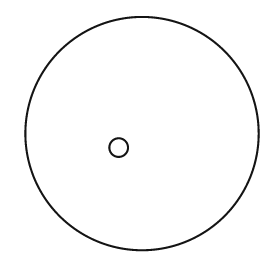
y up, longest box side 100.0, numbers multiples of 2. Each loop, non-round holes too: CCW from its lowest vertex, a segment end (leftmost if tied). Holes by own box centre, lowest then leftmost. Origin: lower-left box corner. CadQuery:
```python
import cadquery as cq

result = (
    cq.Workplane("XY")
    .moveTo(50.0, 50.0)
    .circle(50.0)
    .moveTo(40.0, 44.0)
    .circle(4.0)
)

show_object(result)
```